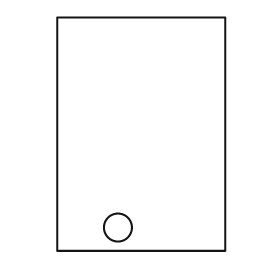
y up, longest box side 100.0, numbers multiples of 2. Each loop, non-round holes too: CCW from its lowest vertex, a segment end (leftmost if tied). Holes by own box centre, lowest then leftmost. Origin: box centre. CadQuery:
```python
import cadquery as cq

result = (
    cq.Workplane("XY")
    .moveTo(-36.0, -50.0)
    .lineTo(36.0, -50.0)
    .lineTo(36.0, 50.0)
    .lineTo(-36.0, 50.0)
    .close()
    .moveTo(-10.0, -40.0)
    .circle(6.0)
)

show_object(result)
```